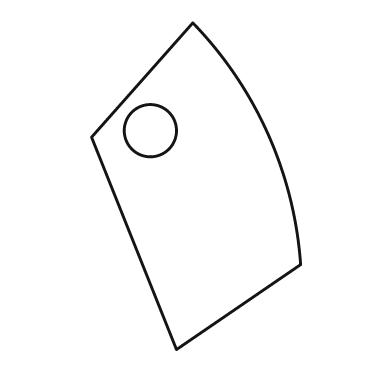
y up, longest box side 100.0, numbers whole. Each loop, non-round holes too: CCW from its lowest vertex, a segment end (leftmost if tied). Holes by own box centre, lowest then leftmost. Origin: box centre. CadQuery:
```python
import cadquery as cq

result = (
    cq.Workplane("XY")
    .moveTo(-6.0, -50.0)
    .lineTo(32.0, -24.0)
    .threePointArc((22.0, 16.0), (-1.0, 50.0))
    .lineTo(-32.0, 15.0)
    .close()
    .moveTo(-14.0, 17.0)
    .circle(8.0)
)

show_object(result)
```